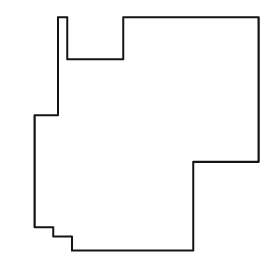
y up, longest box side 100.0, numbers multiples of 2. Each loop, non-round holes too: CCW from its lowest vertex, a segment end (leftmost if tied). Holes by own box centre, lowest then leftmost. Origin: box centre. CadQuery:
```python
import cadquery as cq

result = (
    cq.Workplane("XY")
    .moveTo(-32.0, -50.0)
    .lineTo(20.0, -50.0)
    .lineTo(20.0, -12.0)
    .lineTo(48.0, -12.0)
    .lineTo(48.0, 50.0)
    .lineTo(-10.0, 50.0)
    .lineTo(-10.0, 32.0)
    .lineTo(-34.0, 32.0)
    .lineTo(-34.0, 50.0)
    .lineTo(-38.0, 50.0)
    .lineTo(-38.0, 8.0)
    .lineTo(-48.0, 8.0)
    .lineTo(-48.0, -40.0)
    .lineTo(-40.0, -40.0)
    .lineTo(-40.0, -44.0)
    .lineTo(-32.0, -44.0)
    .close()
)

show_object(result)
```